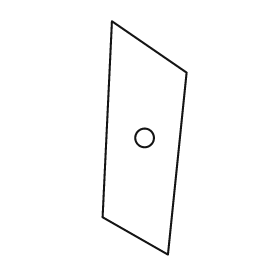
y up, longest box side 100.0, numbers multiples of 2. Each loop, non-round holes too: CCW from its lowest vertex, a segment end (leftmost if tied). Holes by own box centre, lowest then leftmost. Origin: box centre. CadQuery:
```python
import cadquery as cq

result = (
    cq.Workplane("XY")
    .moveTo(10.0, -50.0)
    .lineTo(18.0, 28.0)
    .lineTo(-14.0, 50.0)
    .lineTo(-18.0, -34.0)
    .close()
    .moveTo(0.0, 0.0)
    .circle(4.0)
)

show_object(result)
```